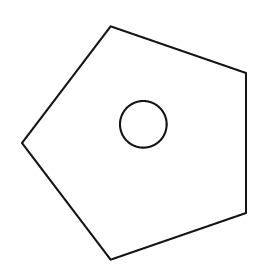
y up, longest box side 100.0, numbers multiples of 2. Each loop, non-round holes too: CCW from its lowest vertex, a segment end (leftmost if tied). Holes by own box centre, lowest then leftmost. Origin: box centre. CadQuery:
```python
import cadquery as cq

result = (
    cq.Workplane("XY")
    .moveTo(-10.0, -50.0)
    .lineTo(48.0, -30.0)
    .lineTo(48.0, 30.0)
    .lineTo(-10.0, 50.0)
    .lineTo(-48.0, 0.0)
    .close()
    .moveTo(4.0, 8.0)
    .circle(10.0)
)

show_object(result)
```